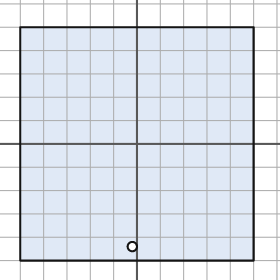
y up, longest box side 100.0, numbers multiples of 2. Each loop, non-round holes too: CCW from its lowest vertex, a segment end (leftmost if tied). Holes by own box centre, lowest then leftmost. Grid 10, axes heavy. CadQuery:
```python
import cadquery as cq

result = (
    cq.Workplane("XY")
    .moveTo(-50.0, -50.0)
    .lineTo(50.0, -50.0)
    .lineTo(50.0, 50.0)
    .lineTo(-50.0, 50.0)
    .close()
    .moveTo(-2.0, -44.0)
    .circle(2.0)
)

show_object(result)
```